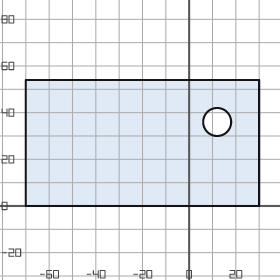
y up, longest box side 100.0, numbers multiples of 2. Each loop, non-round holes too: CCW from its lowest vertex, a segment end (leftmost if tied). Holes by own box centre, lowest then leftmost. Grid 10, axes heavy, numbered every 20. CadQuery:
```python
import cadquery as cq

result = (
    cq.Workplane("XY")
    .moveTo(-70.0, 0.0)
    .lineTo(30.0, 0.0)
    .lineTo(30.0, 54.0)
    .lineTo(-70.0, 54.0)
    .close()
    .moveTo(12.0, 36.0)
    .circle(6.0)
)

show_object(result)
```